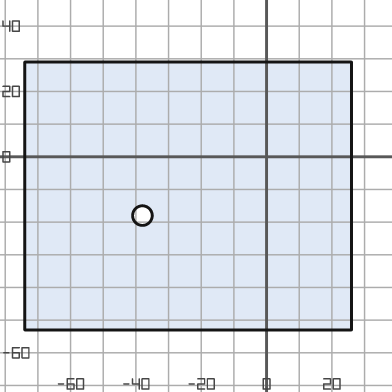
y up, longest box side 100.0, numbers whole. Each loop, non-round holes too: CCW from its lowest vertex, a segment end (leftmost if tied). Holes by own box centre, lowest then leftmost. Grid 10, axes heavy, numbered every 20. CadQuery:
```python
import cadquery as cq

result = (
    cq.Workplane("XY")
    .moveTo(-74.0, -53.0)
    .lineTo(26.0, -53.0)
    .lineTo(26.0, 29.0)
    .lineTo(-74.0, 29.0)
    .close()
    .moveTo(-38.0, -18.0)
    .circle(3.0)
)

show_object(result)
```